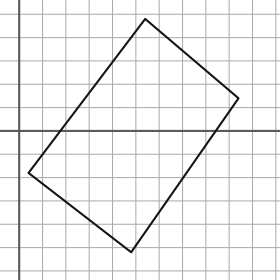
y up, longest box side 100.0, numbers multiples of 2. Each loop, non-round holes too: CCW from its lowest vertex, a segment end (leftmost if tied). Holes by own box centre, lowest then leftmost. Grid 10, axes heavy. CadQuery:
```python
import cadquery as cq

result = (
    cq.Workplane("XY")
    .moveTo(48.0, -52.0)
    .lineTo(94.0, 14.0)
    .lineTo(54.0, 48.0)
    .lineTo(4.0, -18.0)
    .close()
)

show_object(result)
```